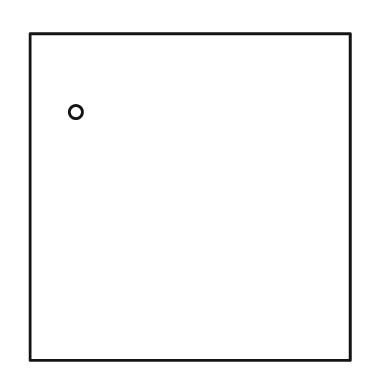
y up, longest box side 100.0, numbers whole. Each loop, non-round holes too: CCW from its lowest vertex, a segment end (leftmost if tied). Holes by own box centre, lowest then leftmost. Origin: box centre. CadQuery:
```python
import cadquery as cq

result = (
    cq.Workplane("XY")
    .moveTo(-49.0, -50.0)
    .lineTo(49.0, -50.0)
    .lineTo(49.0, 50.0)
    .lineTo(-49.0, 50.0)
    .close()
    .moveTo(-35.0, 26.0)
    .circle(2.0)
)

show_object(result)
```